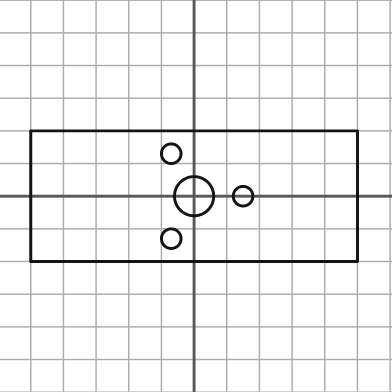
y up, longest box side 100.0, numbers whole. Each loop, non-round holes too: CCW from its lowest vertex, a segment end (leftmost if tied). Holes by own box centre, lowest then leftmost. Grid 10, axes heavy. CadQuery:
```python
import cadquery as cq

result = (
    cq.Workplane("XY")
    .moveTo(-50.0, -20.0)
    .lineTo(50.0, -20.0)
    .lineTo(50.0, 20.0)
    .lineTo(-50.0, 20.0)
    .close()
    .moveTo(-7.0, -13.0)
    .circle(3.0)
    .moveTo(0.0, 0.0)
    .circle(6.0)
    .moveTo(15.0, 0.0)
    .circle(3.0)
    .moveTo(-7.0, 13.0)
    .circle(3.0)
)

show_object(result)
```